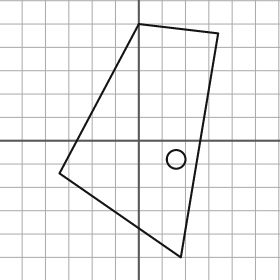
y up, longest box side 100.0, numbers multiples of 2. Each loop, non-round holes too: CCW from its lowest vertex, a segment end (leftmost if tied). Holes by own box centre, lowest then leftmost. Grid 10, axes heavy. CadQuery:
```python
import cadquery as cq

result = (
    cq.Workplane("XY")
    .moveTo(18.0, -50.0)
    .lineTo(34.0, 46.0)
    .lineTo(0.0, 50.0)
    .lineTo(-34.0, -14.0)
    .close()
    .moveTo(16.0, -8.0)
    .circle(4.0)
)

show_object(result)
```